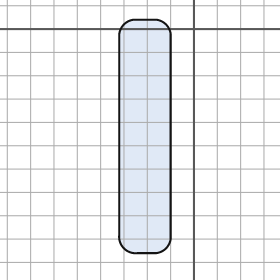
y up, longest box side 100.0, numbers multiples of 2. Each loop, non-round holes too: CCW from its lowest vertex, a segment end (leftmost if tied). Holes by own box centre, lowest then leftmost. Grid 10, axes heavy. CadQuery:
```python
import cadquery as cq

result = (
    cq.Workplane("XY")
    .moveTo(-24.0, -96.0)
    .lineTo(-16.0, -96.0)
    .threePointArc((-12.0, -94.0), (-10.0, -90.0))
    .lineTo(-10.0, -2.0)
    .threePointArc((-12.0, 2.0), (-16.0, 4.0))
    .lineTo(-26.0, 4.0)
    .threePointArc((-30.0, 2.0), (-32.0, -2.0))
    .lineTo(-32.0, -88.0)
    .threePointArc((-30.0, -94.0), (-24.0, -96.0))
    .close()
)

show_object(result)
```